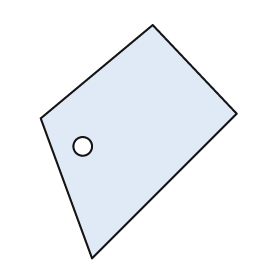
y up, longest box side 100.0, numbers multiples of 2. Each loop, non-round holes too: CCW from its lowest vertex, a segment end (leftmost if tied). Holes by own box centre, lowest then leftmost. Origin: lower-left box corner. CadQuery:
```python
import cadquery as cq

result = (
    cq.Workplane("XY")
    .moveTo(22.0, 0.0)
    .lineTo(84.0, 62.0)
    .lineTo(48.0, 100.0)
    .lineTo(0.0, 60.0)
    .close()
    .moveTo(18.0, 48.0)
    .circle(4.0)
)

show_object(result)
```